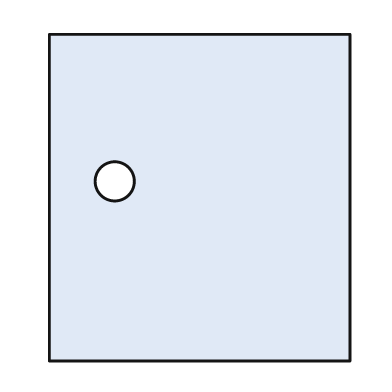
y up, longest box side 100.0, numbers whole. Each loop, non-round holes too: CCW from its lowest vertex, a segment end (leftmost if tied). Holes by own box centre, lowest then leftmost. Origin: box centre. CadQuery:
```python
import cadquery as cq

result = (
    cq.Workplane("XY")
    .moveTo(-46.0, -50.0)
    .lineTo(46.0, -50.0)
    .lineTo(46.0, 50.0)
    .lineTo(-46.0, 50.0)
    .close()
    .moveTo(-26.0, 5.0)
    .circle(6.0)
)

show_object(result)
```